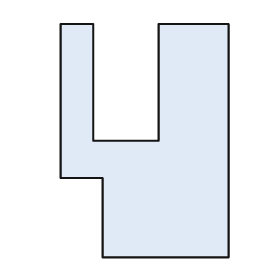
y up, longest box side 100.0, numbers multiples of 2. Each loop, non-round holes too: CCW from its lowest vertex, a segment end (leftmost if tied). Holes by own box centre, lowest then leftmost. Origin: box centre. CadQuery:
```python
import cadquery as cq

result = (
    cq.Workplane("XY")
    .moveTo(-18.0, -50.0)
    .lineTo(36.0, -50.0)
    .lineTo(36.0, 50.0)
    .lineTo(6.0, 50.0)
    .lineTo(6.0, 0.0)
    .lineTo(-22.0, 0.0)
    .lineTo(-22.0, 50.0)
    .lineTo(-36.0, 50.0)
    .lineTo(-36.0, -16.0)
    .lineTo(-18.0, -16.0)
    .close()
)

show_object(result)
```